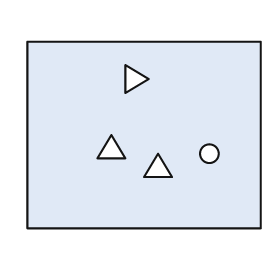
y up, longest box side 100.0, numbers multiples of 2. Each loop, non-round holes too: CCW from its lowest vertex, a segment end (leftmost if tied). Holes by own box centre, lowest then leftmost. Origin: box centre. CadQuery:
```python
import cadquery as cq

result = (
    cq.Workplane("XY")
    .moveTo(-50.0, -40.0)
    .lineTo(50.0, -40.0)
    .lineTo(50.0, 40.0)
    .lineTo(-50.0, 40.0)
    .close()
    .moveTo(0.0, -18.0)
    .lineTo(12.0, -18.0)
    .lineTo(6.0, -8.0)
    .close()
    .moveTo(28.0, -8.0)
    .circle(4.0)
    .moveTo(-20.0, -10.0)
    .lineTo(-8.0, -10.0)
    .lineTo(-14.0, 0.0)
    .close()
    .moveTo(-8.0, 18.0)
    .lineTo(2.0, 24.0)
    .lineTo(-8.0, 30.0)
    .close()
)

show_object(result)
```